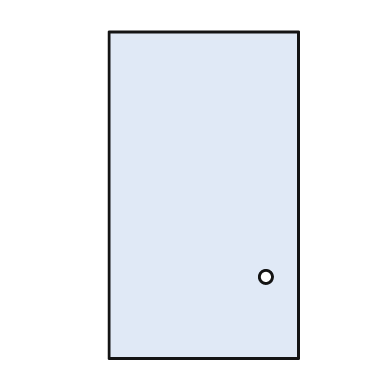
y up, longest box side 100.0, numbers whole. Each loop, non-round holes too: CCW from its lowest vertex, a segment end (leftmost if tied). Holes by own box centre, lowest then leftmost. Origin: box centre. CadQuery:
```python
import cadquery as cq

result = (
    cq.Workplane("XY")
    .moveTo(-29.0, -50.0)
    .lineTo(29.0, -50.0)
    .lineTo(29.0, 50.0)
    .lineTo(-29.0, 50.0)
    .close()
    .moveTo(19.0, -25.0)
    .circle(2.0)
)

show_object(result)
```